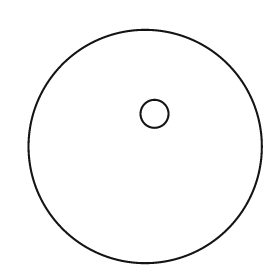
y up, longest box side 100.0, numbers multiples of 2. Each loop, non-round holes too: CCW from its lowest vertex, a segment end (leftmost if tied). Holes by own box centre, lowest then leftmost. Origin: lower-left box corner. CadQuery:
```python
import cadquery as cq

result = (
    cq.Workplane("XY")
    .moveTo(50.0, 50.0)
    .circle(50.0)
    .moveTo(54.0, 64.0)
    .circle(6.0)
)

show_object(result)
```